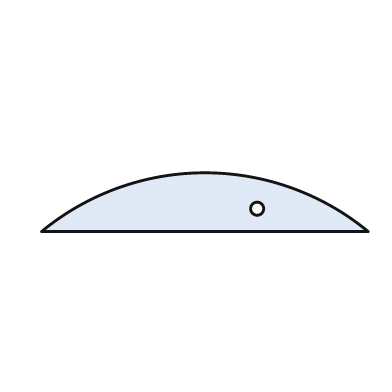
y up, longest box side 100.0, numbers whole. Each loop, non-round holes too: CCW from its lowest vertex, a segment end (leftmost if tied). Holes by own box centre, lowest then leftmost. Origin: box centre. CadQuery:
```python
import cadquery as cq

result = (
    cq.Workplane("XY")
    .moveTo(-50.0, -9.0)
    .lineTo(50.0, -9.0)
    .threePointArc((0.0, 9.0), (-50.0, -9.0))
    .close()
    .moveTo(16.0, -2.0)
    .circle(2.0)
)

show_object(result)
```